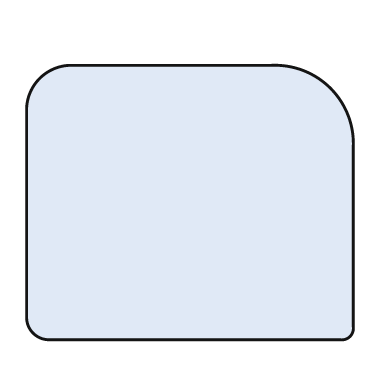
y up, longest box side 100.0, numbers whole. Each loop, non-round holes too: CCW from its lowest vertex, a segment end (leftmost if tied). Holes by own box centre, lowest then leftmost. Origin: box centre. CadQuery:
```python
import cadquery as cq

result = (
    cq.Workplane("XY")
    .moveTo(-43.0, -42.0)
    .lineTo(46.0, -42.0)
    .threePointArc((49.0, -41.0), (50.0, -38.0))
    .lineTo(50.0, 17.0)
    .threePointArc((43.0, 35.0), (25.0, 42.0))
    .lineTo(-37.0, 42.0)
    .threePointArc((-46.0, 38.0), (-50.0, 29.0))
    .lineTo(-50.0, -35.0)
    .threePointArc((-48.0, -40.0), (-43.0, -42.0))
    .close()
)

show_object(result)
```